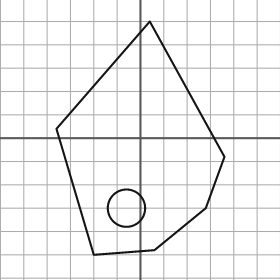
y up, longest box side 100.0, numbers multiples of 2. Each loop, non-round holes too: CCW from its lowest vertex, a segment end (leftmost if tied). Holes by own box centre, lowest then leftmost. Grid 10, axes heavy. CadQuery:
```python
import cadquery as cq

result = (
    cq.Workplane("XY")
    .moveTo(-20.0, -50.0)
    .lineTo(6.0, -48.0)
    .lineTo(28.0, -30.0)
    .lineTo(36.0, -8.0)
    .lineTo(4.0, 50.0)
    .lineTo(-36.0, 4.0)
    .close()
    .moveTo(-6.0, -30.0)
    .circle(8.0)
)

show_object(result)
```